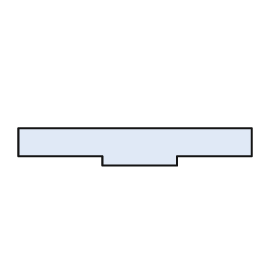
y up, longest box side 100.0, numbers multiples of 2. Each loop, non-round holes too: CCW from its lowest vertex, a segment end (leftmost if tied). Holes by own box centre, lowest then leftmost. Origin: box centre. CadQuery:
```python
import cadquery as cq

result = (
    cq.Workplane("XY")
    .moveTo(-14.0, -8.0)
    .lineTo(18.0, -8.0)
    .lineTo(18.0, -4.0)
    .lineTo(50.0, -4.0)
    .lineTo(50.0, 8.0)
    .lineTo(-50.0, 8.0)
    .lineTo(-50.0, -4.0)
    .lineTo(-14.0, -4.0)
    .close()
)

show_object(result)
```